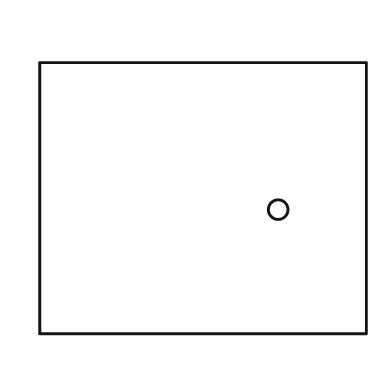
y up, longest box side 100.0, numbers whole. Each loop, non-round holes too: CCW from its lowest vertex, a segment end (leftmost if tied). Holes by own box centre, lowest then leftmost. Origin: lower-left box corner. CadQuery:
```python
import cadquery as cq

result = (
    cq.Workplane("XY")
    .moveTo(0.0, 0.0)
    .lineTo(100.0, 0.0)
    .lineTo(100.0, 83.0)
    .lineTo(0.0, 83.0)
    .close()
    .moveTo(73.0, 38.0)
    .circle(3.0)
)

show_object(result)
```